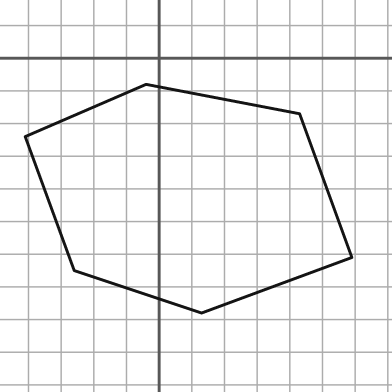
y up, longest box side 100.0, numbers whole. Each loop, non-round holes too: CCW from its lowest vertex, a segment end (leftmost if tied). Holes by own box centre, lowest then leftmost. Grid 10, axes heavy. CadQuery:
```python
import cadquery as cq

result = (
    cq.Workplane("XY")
    .moveTo(13.0, -78.0)
    .lineTo(59.0, -61.0)
    .lineTo(43.0, -17.0)
    .lineTo(-4.0, -8.0)
    .lineTo(-41.0, -24.0)
    .lineTo(-26.0, -65.0)
    .close()
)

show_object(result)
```